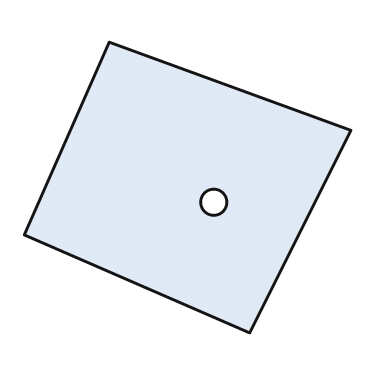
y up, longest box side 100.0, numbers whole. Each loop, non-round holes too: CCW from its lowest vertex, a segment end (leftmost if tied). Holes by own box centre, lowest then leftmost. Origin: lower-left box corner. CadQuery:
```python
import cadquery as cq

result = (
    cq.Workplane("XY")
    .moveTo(69.0, 0.0)
    .lineTo(100.0, 62.0)
    .lineTo(26.0, 89.0)
    .lineTo(0.0, 30.0)
    .close()
    .moveTo(58.0, 40.0)
    .circle(4.0)
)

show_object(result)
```